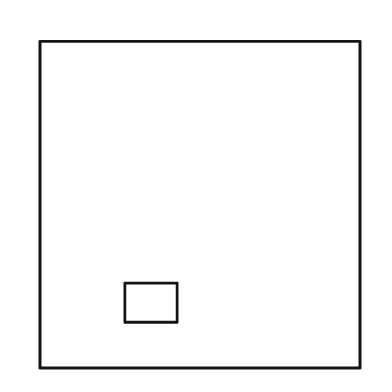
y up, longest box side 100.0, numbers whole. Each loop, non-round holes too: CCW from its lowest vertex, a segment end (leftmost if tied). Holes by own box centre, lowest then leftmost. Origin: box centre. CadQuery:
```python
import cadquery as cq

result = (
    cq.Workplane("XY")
    .moveTo(-49.0, -50.0)
    .lineTo(49.0, -50.0)
    .lineTo(49.0, 50.0)
    .lineTo(-49.0, 50.0)
    .close()
    .moveTo(-23.0, -36.0)
    .lineTo(-7.0, -36.0)
    .lineTo(-7.0, -24.0)
    .lineTo(-23.0, -24.0)
    .close()
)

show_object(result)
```